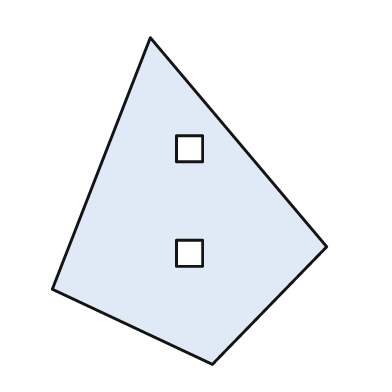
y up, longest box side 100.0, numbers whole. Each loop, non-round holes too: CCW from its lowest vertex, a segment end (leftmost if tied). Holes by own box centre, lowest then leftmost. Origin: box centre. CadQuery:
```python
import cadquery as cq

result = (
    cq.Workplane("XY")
    .moveTo(7.0, -50.0)
    .lineTo(42.0, -14.0)
    .lineTo(-12.0, 50.0)
    .lineTo(-42.0, -27.0)
    .close()
    .moveTo(-4.0, -20.0)
    .lineTo(4.0, -20.0)
    .lineTo(4.0, -12.0)
    .lineTo(-4.0, -12.0)
    .close()
    .moveTo(-4.0, 12.0)
    .lineTo(4.0, 12.0)
    .lineTo(4.0, 20.0)
    .lineTo(-4.0, 20.0)
    .close()
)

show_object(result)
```